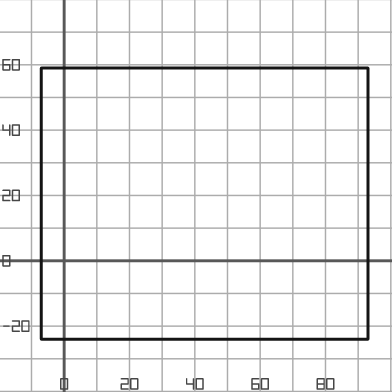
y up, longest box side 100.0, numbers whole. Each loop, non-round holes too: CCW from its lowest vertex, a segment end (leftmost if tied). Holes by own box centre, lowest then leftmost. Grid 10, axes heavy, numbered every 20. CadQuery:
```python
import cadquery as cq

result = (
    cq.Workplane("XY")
    .moveTo(-7.0, -24.0)
    .lineTo(93.0, -24.0)
    .lineTo(93.0, 59.0)
    .lineTo(-7.0, 59.0)
    .close()
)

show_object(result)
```